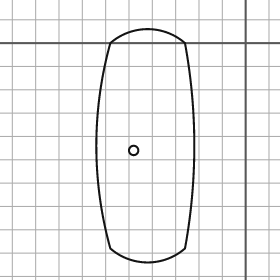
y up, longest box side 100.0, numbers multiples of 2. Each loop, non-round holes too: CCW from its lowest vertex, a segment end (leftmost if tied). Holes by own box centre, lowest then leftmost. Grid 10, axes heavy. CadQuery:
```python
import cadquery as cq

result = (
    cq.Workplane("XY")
    .moveTo(-58.0, -88.0)
    .threePointArc((-42.0, -94.0), (-26.0, -88.0))
    .threePointArc((-22.0, -44.0), (-26.0, 0.0))
    .threePointArc((-42.0, 6.0), (-58.0, 0.0))
    .threePointArc((-64.0, -44.0), (-58.0, -88.0))
    .close()
    .moveTo(-48.0, -46.0)
    .circle(2.0)
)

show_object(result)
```